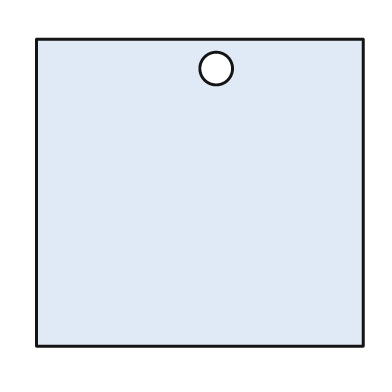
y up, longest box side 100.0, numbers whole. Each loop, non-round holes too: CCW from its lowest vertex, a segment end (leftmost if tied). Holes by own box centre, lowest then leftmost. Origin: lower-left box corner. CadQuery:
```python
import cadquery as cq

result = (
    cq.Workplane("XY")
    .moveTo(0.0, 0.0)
    .lineTo(100.0, 0.0)
    .lineTo(100.0, 94.0)
    .lineTo(0.0, 94.0)
    .close()
    .moveTo(55.0, 85.0)
    .circle(5.0)
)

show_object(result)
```